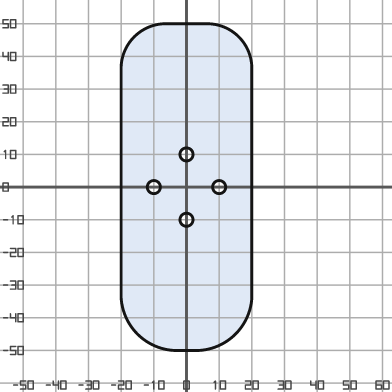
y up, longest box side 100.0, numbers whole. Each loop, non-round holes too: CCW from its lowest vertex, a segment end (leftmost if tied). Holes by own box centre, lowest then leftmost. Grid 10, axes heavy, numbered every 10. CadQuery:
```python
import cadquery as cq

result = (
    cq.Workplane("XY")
    .moveTo(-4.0, -50.0)
    .lineTo(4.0, -50.0)
    .threePointArc((15.0, -45.0), (20.0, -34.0))
    .lineTo(20.0, 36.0)
    .threePointArc((16.0, 46.0), (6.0, 50.0))
    .lineTo(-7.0, 50.0)
    .threePointArc((-16.0, 46.0), (-20.0, 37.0))
    .lineTo(-20.0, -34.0)
    .threePointArc((-15.0, -45.0), (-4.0, -50.0))
    .close()
    .moveTo(0.0, -10.0)
    .circle(2.0)
    .moveTo(-10.0, 0.0)
    .circle(2.0)
    .moveTo(10.0, 0.0)
    .circle(2.0)
    .moveTo(0.0, 10.0)
    .circle(2.0)
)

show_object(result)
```